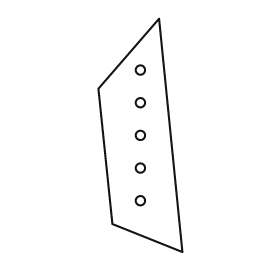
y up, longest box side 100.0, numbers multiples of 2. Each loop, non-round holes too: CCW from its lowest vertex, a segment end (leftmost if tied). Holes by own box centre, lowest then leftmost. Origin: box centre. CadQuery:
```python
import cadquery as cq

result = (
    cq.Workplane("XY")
    .moveTo(18.0, -50.0)
    .lineTo(8.0, 50.0)
    .lineTo(-18.0, 20.0)
    .lineTo(-12.0, -38.0)
    .close()
    .moveTo(0.0, -28.0)
    .circle(2.0)
    .moveTo(0.0, -14.0)
    .circle(2.0)
    .moveTo(0.0, 0.0)
    .circle(2.0)
    .moveTo(0.0, 14.0)
    .circle(2.0)
    .moveTo(0.0, 28.0)
    .circle(2.0)
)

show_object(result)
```